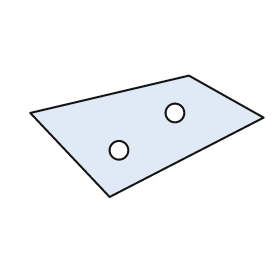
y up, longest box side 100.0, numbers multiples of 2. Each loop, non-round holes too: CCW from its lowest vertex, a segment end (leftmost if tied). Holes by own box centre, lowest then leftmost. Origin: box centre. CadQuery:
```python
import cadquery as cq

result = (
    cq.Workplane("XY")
    .moveTo(-16.0, -26.0)
    .lineTo(50.0, 8.0)
    .lineTo(18.0, 26.0)
    .lineTo(-50.0, 10.0)
    .close()
    .moveTo(-12.0, -6.0)
    .circle(4.0)
    .moveTo(12.0, 10.0)
    .circle(4.0)
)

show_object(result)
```